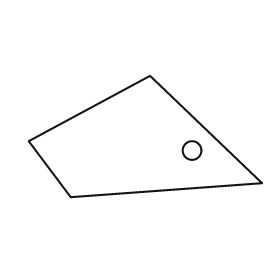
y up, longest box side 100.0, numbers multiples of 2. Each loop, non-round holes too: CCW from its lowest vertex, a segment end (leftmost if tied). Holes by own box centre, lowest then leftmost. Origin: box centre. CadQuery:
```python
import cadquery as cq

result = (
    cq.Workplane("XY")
    .moveTo(-32.0, -26.0)
    .lineTo(50.0, -20.0)
    .lineTo(2.0, 26.0)
    .lineTo(-50.0, -2.0)
    .close()
    .moveTo(20.0, -6.0)
    .circle(4.0)
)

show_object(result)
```